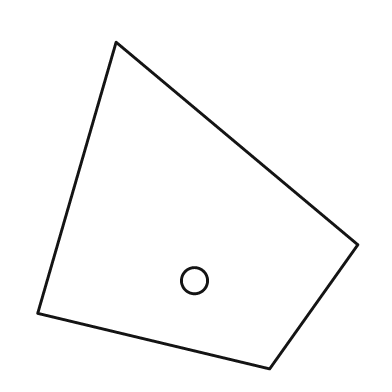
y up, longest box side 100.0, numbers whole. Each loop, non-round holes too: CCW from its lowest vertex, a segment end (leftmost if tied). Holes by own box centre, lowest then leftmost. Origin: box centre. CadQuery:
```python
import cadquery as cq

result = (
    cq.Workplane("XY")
    .moveTo(22.0, -50.0)
    .lineTo(49.0, -12.0)
    .lineTo(-25.0, 50.0)
    .lineTo(-49.0, -33.0)
    .close()
    .moveTo(-1.0, -23.0)
    .circle(4.0)
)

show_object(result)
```